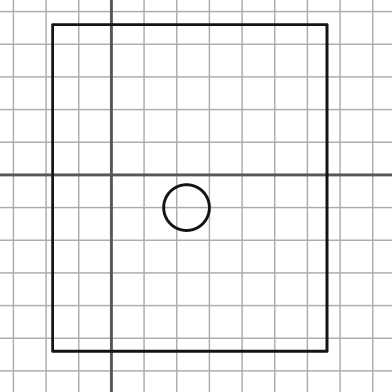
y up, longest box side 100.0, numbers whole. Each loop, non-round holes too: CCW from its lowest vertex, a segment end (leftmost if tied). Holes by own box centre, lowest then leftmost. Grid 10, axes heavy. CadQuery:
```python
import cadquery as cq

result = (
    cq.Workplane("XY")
    .moveTo(-18.0, -54.0)
    .lineTo(66.0, -54.0)
    .lineTo(66.0, 46.0)
    .lineTo(-18.0, 46.0)
    .close()
    .moveTo(23.0, -10.0)
    .circle(7.0)
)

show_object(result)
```